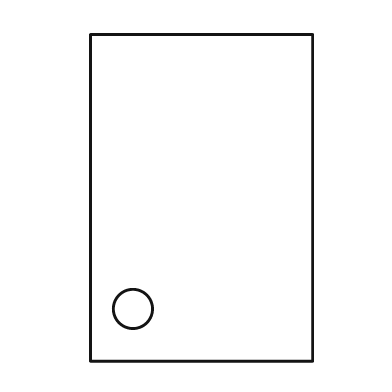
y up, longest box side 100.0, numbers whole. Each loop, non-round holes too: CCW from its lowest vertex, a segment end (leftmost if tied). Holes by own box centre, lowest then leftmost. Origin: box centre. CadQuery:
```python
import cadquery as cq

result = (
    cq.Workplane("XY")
    .moveTo(-34.0, -50.0)
    .lineTo(34.0, -50.0)
    .lineTo(34.0, 50.0)
    .lineTo(-34.0, 50.0)
    .close()
    .moveTo(-21.0, -34.0)
    .circle(6.0)
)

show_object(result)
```